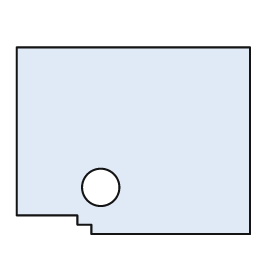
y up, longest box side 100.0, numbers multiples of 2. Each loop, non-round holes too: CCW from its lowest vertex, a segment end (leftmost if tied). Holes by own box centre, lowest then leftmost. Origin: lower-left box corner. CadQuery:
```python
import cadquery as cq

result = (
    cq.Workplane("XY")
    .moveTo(32.0, 0.0)
    .lineTo(100.0, 0.0)
    .lineTo(100.0, 80.0)
    .lineTo(0.0, 80.0)
    .lineTo(0.0, 8.0)
    .lineTo(26.0, 8.0)
    .lineTo(26.0, 4.0)
    .lineTo(32.0, 4.0)
    .close()
    .moveTo(36.0, 20.0)
    .circle(8.0)
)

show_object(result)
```